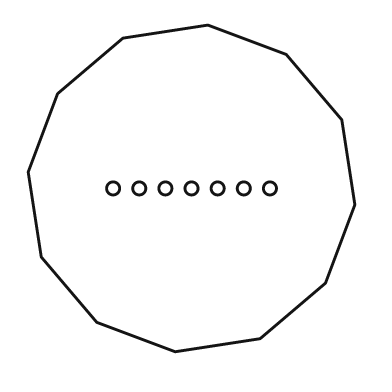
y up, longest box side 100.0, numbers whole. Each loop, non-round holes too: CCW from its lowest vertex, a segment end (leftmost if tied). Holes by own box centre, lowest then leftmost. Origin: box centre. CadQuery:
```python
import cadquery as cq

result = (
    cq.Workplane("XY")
    .moveTo(-5.0, -50.0)
    .lineTo(21.0, -46.0)
    .lineTo(41.0, -29.0)
    .lineTo(50.0, -5.0)
    .lineTo(46.0, 21.0)
    .lineTo(29.0, 41.0)
    .lineTo(5.0, 50.0)
    .lineTo(-21.0, 46.0)
    .lineTo(-41.0, 29.0)
    .lineTo(-50.0, 5.0)
    .lineTo(-46.0, -21.0)
    .lineTo(-29.0, -41.0)
    .close()
    .moveTo(-24.0, 0.0)
    .circle(2.0)
    .moveTo(-16.0, 0.0)
    .circle(2.0)
    .moveTo(-8.0, 0.0)
    .circle(2.0)
    .moveTo(0.0, 0.0)
    .circle(2.0)
    .moveTo(8.0, 0.0)
    .circle(2.0)
    .moveTo(16.0, 0.0)
    .circle(2.0)
    .moveTo(24.0, 0.0)
    .circle(2.0)
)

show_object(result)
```